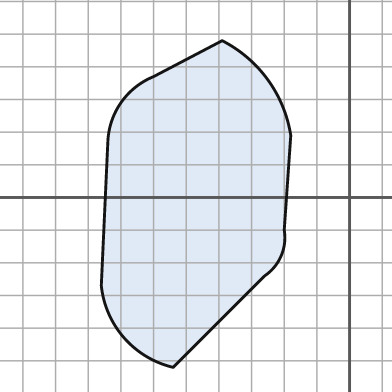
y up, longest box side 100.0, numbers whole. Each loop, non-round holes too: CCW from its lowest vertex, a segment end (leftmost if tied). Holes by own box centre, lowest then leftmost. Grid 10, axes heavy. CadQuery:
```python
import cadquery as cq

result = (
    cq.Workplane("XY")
    .moveTo(-54.0, -52.0)
    .lineTo(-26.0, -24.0)
    .threePointArc((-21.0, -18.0), (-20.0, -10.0))
    .lineTo(-18.0, 19.0)
    .threePointArc((-25.0, 36.0), (-39.0, 48.0))
    .lineTo(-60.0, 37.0)
    .threePointArc((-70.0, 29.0), (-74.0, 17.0))
    .lineTo(-76.0, -27.0)
    .threePointArc((-69.0, -43.0), (-54.0, -52.0))
    .close()
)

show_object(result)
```